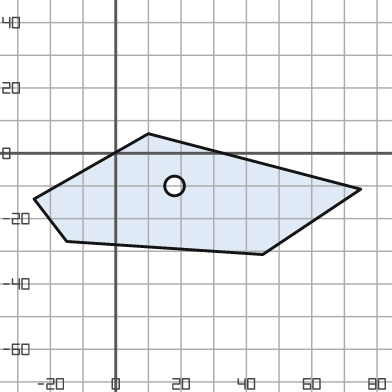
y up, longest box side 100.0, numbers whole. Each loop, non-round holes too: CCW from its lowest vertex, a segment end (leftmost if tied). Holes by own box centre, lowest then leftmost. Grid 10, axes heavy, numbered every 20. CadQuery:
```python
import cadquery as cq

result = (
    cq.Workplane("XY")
    .moveTo(45.0, -31.0)
    .lineTo(75.0, -11.0)
    .lineTo(10.0, 6.0)
    .lineTo(-25.0, -14.0)
    .lineTo(-15.0, -27.0)
    .close()
    .moveTo(18.0, -10.0)
    .circle(3.0)
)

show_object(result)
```